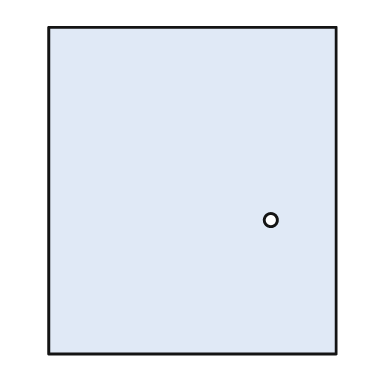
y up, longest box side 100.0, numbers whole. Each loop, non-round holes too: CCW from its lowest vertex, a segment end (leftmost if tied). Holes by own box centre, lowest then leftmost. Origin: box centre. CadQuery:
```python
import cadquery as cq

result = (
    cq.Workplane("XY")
    .moveTo(-44.0, -50.0)
    .lineTo(44.0, -50.0)
    .lineTo(44.0, 50.0)
    .lineTo(-44.0, 50.0)
    .close()
    .moveTo(24.0, -9.0)
    .circle(2.0)
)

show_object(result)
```